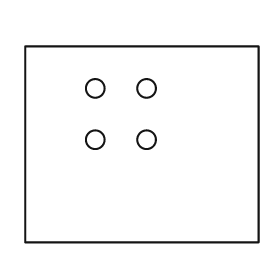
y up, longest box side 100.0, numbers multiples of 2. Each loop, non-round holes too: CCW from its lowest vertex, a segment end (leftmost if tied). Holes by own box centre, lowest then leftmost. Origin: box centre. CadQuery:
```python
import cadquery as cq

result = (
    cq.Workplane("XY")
    .moveTo(-50.0, -42.0)
    .lineTo(50.0, -42.0)
    .lineTo(50.0, 42.0)
    .lineTo(-50.0, 42.0)
    .close()
    .moveTo(-20.0, 2.0)
    .circle(4.0)
    .moveTo(2.0, 2.0)
    .circle(4.0)
    .moveTo(-20.0, 24.0)
    .circle(4.0)
    .moveTo(2.0, 24.0)
    .circle(4.0)
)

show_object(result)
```